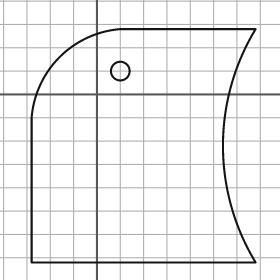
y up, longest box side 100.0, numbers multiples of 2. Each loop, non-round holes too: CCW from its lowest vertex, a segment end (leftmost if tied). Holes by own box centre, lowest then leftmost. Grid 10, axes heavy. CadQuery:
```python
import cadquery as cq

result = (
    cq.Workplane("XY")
    .moveTo(-28.0, -72.0)
    .lineTo(68.0, -72.0)
    .threePointArc((54.0, -22.0), (68.0, 28.0))
    .lineTo(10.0, 28.0)
    .threePointArc((-16.0, 16.0), (-28.0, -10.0))
    .close()
    .moveTo(10.0, 10.0)
    .circle(4.0)
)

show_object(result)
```